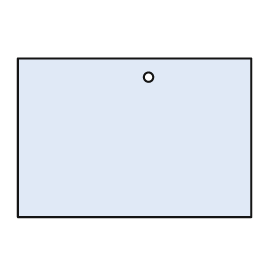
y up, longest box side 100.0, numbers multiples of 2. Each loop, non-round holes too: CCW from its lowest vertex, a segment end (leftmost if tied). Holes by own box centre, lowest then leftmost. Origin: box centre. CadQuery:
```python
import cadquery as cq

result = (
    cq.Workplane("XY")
    .moveTo(-50.0, -34.0)
    .lineTo(50.0, -34.0)
    .lineTo(50.0, 34.0)
    .lineTo(-50.0, 34.0)
    .close()
    .moveTo(6.0, 26.0)
    .circle(2.0)
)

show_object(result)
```